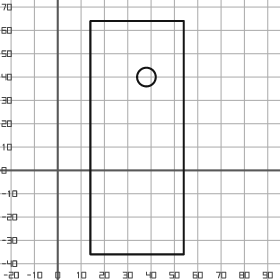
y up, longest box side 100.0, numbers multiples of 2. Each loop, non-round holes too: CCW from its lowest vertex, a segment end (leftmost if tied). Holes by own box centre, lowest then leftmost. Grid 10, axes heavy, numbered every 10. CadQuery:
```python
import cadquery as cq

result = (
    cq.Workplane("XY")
    .moveTo(14.0, -36.0)
    .lineTo(54.0, -36.0)
    .lineTo(54.0, 64.0)
    .lineTo(14.0, 64.0)
    .close()
    .moveTo(38.0, 40.0)
    .circle(4.0)
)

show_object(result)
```